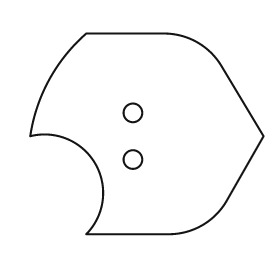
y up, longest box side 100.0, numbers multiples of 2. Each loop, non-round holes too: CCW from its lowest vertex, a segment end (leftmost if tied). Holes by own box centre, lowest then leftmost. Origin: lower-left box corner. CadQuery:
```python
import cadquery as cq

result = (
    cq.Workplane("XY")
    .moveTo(24.0, 0.0)
    .lineTo(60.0, 0.0)
    .threePointArc((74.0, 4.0), (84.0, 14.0))
    .lineTo(100.0, 42.0)
    .lineTo(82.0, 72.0)
    .threePointArc((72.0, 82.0), (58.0, 86.0))
    .lineTo(24.0, 86.0)
    .threePointArc((8.0, 66.0), (0.0, 42.0))
    .threePointArc((28.0, 30.0), (24.0, 0.0))
    .close()
    .moveTo(44.0, 32.0)
    .circle(4.0)
    .moveTo(44.0, 52.0)
    .circle(4.0)
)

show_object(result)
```